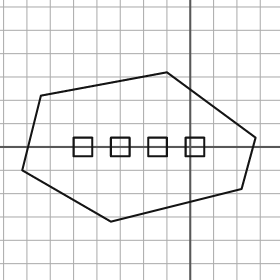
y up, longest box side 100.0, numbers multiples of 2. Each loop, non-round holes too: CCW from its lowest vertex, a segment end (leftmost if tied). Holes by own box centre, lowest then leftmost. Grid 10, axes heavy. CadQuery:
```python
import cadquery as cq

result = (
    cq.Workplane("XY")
    .moveTo(-34.0, -32.0)
    .lineTo(22.0, -18.0)
    .lineTo(28.0, 4.0)
    .lineTo(-10.0, 32.0)
    .lineTo(-64.0, 22.0)
    .lineTo(-72.0, -10.0)
    .close()
    .moveTo(-50.0, -4.0)
    .lineTo(-42.0, -4.0)
    .lineTo(-42.0, 4.0)
    .lineTo(-50.0, 4.0)
    .close()
    .moveTo(-34.0, -4.0)
    .lineTo(-26.0, -4.0)
    .lineTo(-26.0, 4.0)
    .lineTo(-34.0, 4.0)
    .close()
    .moveTo(-18.0, -4.0)
    .lineTo(-10.0, -4.0)
    .lineTo(-10.0, 4.0)
    .lineTo(-18.0, 4.0)
    .close()
    .moveTo(-2.0, -4.0)
    .lineTo(6.0, -4.0)
    .lineTo(6.0, 4.0)
    .lineTo(-2.0, 4.0)
    .close()
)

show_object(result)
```